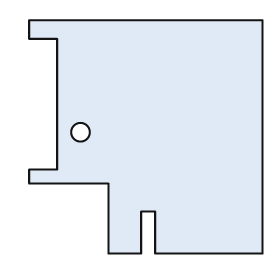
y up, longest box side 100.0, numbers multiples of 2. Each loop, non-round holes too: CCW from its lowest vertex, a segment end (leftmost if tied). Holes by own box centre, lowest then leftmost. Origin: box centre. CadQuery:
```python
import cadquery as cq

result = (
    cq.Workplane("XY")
    .moveTo(-16.0, -50.0)
    .lineTo(-2.0, -50.0)
    .lineTo(-2.0, -32.0)
    .lineTo(4.0, -32.0)
    .lineTo(4.0, -50.0)
    .lineTo(50.0, -50.0)
    .lineTo(50.0, 50.0)
    .lineTo(-50.0, 50.0)
    .lineTo(-50.0, 42.0)
    .lineTo(-38.0, 42.0)
    .lineTo(-38.0, -14.0)
    .lineTo(-50.0, -14.0)
    .lineTo(-50.0, -20.0)
    .lineTo(-16.0, -20.0)
    .close()
    .moveTo(-28.0, 2.0)
    .circle(4.0)
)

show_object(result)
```